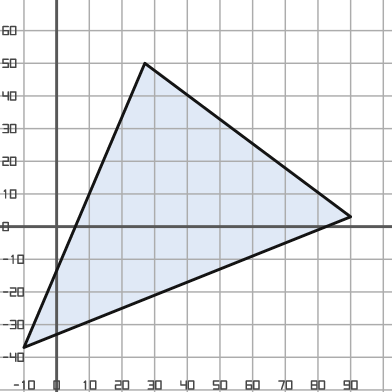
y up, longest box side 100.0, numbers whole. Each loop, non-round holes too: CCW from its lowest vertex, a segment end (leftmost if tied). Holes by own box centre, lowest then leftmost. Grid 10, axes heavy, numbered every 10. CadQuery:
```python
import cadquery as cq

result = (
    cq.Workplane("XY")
    .moveTo(-10.0, -37.0)
    .lineTo(90.0, 3.0)
    .lineTo(27.0, 50.0)
    .close()
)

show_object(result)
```